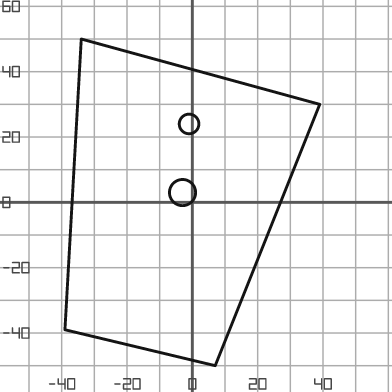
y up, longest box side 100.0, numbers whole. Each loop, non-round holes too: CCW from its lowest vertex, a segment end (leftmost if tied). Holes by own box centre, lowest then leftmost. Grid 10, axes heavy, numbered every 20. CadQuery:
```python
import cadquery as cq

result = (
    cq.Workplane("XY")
    .moveTo(7.0, -50.0)
    .lineTo(39.0, 30.0)
    .lineTo(-34.0, 50.0)
    .lineTo(-39.0, -39.0)
    .close()
    .moveTo(-3.0, 3.0)
    .circle(4.0)
    .moveTo(-1.0, 24.0)
    .circle(3.0)
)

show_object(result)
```